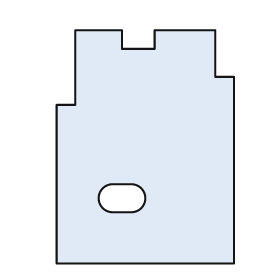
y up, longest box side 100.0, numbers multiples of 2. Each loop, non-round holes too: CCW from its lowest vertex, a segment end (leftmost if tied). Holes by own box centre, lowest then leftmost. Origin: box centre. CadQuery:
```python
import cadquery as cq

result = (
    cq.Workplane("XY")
    .moveTo(-38.0, -50.0)
    .lineTo(38.0, -50.0)
    .lineTo(38.0, 30.0)
    .lineTo(30.0, 30.0)
    .lineTo(30.0, 50.0)
    .lineTo(4.0, 50.0)
    .lineTo(4.0, 42.0)
    .lineTo(-10.0, 42.0)
    .lineTo(-10.0, 50.0)
    .lineTo(-30.0, 50.0)
    .lineTo(-30.0, 18.0)
    .lineTo(-38.0, 18.0)
    .close()
    .moveTo(-14.0, -28.0)
    .lineTo(-6.0, -28.0)
    .threePointArc((0.0, -22.0), (-6.0, -16.0))
    .lineTo(-14.0, -16.0)
    .threePointArc((-20.0, -22.0), (-14.0, -28.0))
    .close()
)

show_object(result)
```